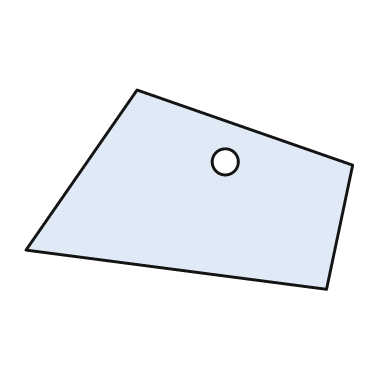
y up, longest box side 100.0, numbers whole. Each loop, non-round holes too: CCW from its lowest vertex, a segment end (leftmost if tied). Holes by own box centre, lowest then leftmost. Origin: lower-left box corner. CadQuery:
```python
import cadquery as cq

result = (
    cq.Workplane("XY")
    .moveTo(92.0, 0.0)
    .lineTo(100.0, 38.0)
    .lineTo(34.0, 61.0)
    .lineTo(0.0, 12.0)
    .close()
    .moveTo(61.0, 39.0)
    .circle(4.0)
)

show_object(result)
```